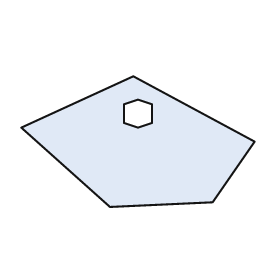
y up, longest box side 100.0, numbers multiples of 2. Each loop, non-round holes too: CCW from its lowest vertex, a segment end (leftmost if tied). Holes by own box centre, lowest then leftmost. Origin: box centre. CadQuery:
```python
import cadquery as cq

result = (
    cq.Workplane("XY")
    .moveTo(-12.0, -28.0)
    .lineTo(32.0, -26.0)
    .lineTo(50.0, 0.0)
    .lineTo(-2.0, 28.0)
    .lineTo(-50.0, 6.0)
    .close()
    .moveTo(0.0, 6.0)
    .lineTo(6.0, 8.0)
    .lineTo(6.0, 16.0)
    .lineTo(0.0, 18.0)
    .lineTo(-6.0, 16.0)
    .lineTo(-6.0, 8.0)
    .close()
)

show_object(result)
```